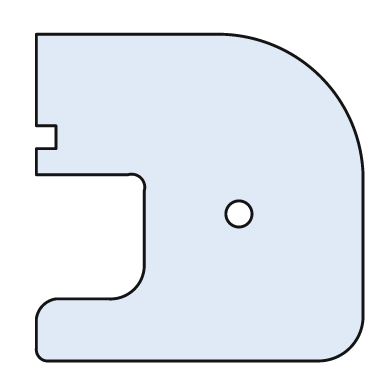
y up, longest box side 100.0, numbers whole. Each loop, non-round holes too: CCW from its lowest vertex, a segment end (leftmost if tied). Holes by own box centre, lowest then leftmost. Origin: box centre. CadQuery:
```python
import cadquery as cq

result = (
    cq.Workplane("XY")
    .moveTo(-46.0, -50.0)
    .lineTo(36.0, -50.0)
    .threePointArc((46.0, -46.0), (50.0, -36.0))
    .lineTo(50.0, 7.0)
    .threePointArc((37.0, 37.0), (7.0, 50.0))
    .lineTo(-50.0, 50.0)
    .lineTo(-50.0, 22.0)
    .lineTo(-44.0, 22.0)
    .lineTo(-44.0, 15.0)
    .lineTo(-50.0, 15.0)
    .lineTo(-50.0, 7.0)
    .lineTo(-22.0, 7.0)
    .threePointArc((-18.0, 6.0), (-17.0, 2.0))
    .lineTo(-17.0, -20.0)
    .threePointArc((-20.0, -28.0), (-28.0, -31.0))
    .lineTo(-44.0, -31.0)
    .threePointArc((-48.0, -33.0), (-50.0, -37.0))
    .lineTo(-50.0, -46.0)
    .threePointArc((-49.0, -49.0), (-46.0, -50.0))
    .close()
    .moveTo(12.0, -5.0)
    .circle(4.0)
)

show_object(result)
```